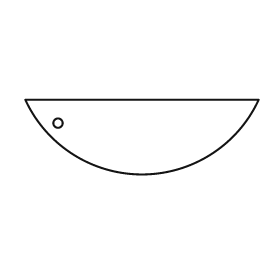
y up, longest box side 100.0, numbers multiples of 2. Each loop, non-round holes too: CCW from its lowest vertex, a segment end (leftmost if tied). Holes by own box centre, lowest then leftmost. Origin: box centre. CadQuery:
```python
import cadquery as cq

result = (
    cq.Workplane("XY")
    .moveTo(-50.0, 16.0)
    .threePointArc((0.0, -16.0), (50.0, 16.0))
    .close()
    .moveTo(-36.0, 6.0)
    .circle(2.0)
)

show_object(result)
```